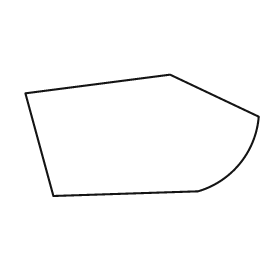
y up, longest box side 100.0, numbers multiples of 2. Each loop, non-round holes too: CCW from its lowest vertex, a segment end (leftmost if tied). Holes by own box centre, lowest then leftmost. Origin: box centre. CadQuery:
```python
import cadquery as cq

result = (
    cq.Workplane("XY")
    .moveTo(-38.0, -26.0)
    .lineTo(24.0, -24.0)
    .threePointArc((42.0, -12.0), (50.0, 8.0))
    .lineTo(12.0, 26.0)
    .lineTo(-50.0, 18.0)
    .close()
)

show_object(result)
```